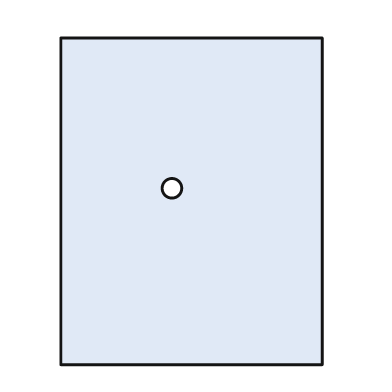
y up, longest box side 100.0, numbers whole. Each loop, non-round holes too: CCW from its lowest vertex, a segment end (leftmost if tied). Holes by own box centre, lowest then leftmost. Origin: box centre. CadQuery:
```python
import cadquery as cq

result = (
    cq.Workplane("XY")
    .moveTo(-40.0, -50.0)
    .lineTo(40.0, -50.0)
    .lineTo(40.0, 50.0)
    .lineTo(-40.0, 50.0)
    .close()
    .moveTo(-6.0, 4.0)
    .circle(3.0)
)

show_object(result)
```